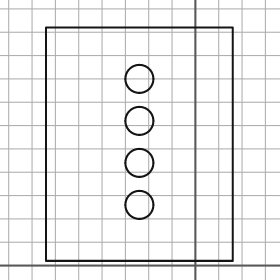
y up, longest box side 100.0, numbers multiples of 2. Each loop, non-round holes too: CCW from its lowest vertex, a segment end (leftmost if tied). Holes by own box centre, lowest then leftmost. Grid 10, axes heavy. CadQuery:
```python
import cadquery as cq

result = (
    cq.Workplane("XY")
    .moveTo(-64.0, 2.0)
    .lineTo(16.0, 2.0)
    .lineTo(16.0, 102.0)
    .lineTo(-64.0, 102.0)
    .close()
    .moveTo(-24.0, 26.0)
    .circle(6.0)
    .moveTo(-24.0, 44.0)
    .circle(6.0)
    .moveTo(-24.0, 62.0)
    .circle(6.0)
    .moveTo(-24.0, 80.0)
    .circle(6.0)
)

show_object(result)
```